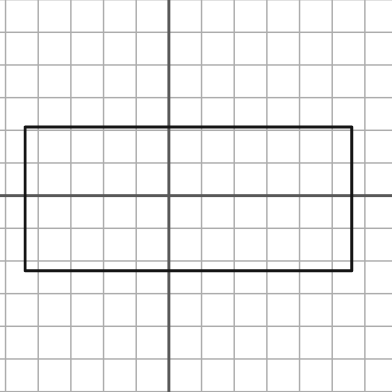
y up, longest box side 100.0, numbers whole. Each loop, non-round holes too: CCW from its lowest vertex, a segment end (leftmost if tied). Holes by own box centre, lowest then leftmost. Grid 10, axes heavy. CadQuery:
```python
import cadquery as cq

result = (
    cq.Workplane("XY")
    .moveTo(-44.0, -23.0)
    .lineTo(56.0, -23.0)
    .lineTo(56.0, 21.0)
    .lineTo(-44.0, 21.0)
    .close()
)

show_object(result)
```